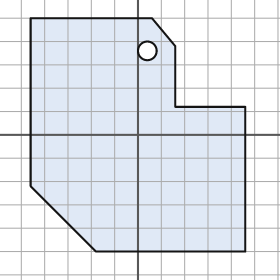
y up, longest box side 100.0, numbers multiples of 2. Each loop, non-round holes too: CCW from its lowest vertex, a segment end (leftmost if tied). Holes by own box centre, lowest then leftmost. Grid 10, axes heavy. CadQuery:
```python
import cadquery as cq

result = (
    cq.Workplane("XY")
    .moveTo(-18.0, -50.0)
    .lineTo(46.0, -50.0)
    .lineTo(46.0, 12.0)
    .lineTo(16.0, 12.0)
    .lineTo(16.0, 38.0)
    .lineTo(6.0, 50.0)
    .lineTo(-46.0, 50.0)
    .lineTo(-46.0, -22.0)
    .close()
    .moveTo(4.0, 36.0)
    .circle(4.0)
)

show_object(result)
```